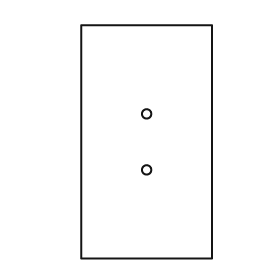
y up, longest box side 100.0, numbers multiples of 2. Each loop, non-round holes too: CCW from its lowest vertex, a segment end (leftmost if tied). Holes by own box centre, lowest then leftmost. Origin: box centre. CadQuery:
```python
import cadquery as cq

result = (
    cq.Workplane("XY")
    .moveTo(-28.0, -50.0)
    .lineTo(28.0, -50.0)
    .lineTo(28.0, 50.0)
    .lineTo(-28.0, 50.0)
    .close()
    .moveTo(0.0, -12.0)
    .circle(2.0)
    .moveTo(0.0, 12.0)
    .circle(2.0)
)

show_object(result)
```